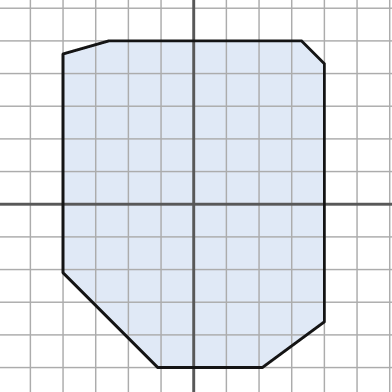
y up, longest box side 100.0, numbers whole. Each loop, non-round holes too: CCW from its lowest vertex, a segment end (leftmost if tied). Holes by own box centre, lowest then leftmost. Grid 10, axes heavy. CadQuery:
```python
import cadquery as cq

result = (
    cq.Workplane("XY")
    .moveTo(-11.0, -50.0)
    .lineTo(21.0, -50.0)
    .lineTo(40.0, -36.0)
    .lineTo(40.0, 43.0)
    .lineTo(33.0, 50.0)
    .lineTo(-26.0, 50.0)
    .lineTo(-40.0, 46.0)
    .lineTo(-40.0, -21.0)
    .close()
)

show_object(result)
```